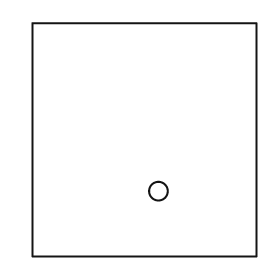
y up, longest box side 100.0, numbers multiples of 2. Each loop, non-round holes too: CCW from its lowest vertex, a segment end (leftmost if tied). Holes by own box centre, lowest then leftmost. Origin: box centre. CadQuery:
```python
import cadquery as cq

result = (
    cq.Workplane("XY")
    .moveTo(-48.0, -50.0)
    .lineTo(48.0, -50.0)
    .lineTo(48.0, 50.0)
    .lineTo(-48.0, 50.0)
    .close()
    .moveTo(6.0, -22.0)
    .circle(4.0)
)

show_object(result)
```